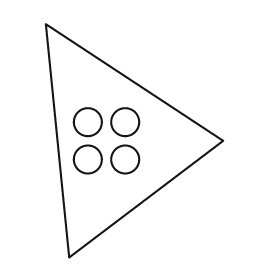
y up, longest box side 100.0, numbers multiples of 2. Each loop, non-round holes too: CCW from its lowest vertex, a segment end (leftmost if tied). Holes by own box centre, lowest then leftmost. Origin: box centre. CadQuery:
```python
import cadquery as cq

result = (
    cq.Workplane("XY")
    .moveTo(-28.0, -50.0)
    .lineTo(38.0, 0.0)
    .lineTo(-38.0, 50.0)
    .close()
    .moveTo(-20.0, -8.0)
    .circle(6.0)
    .moveTo(-4.0, -8.0)
    .circle(6.0)
    .moveTo(-20.0, 8.0)
    .circle(6.0)
    .moveTo(-4.0, 8.0)
    .circle(6.0)
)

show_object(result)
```